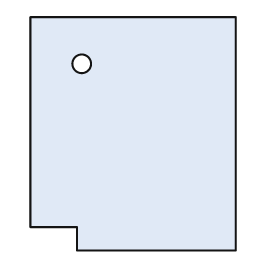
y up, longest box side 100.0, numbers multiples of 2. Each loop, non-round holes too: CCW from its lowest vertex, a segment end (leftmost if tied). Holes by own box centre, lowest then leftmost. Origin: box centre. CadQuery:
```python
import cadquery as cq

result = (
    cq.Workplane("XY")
    .moveTo(-24.0, -50.0)
    .lineTo(44.0, -50.0)
    .lineTo(44.0, 50.0)
    .lineTo(-44.0, 50.0)
    .lineTo(-44.0, -40.0)
    .lineTo(-24.0, -40.0)
    .close()
    .moveTo(-22.0, 30.0)
    .circle(4.0)
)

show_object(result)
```